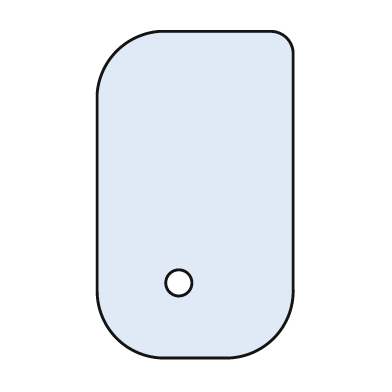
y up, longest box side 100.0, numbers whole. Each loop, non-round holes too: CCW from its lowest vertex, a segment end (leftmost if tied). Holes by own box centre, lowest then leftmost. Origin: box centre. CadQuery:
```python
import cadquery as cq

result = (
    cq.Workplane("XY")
    .moveTo(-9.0, -50.0)
    .lineTo(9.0, -50.0)
    .threePointArc((24.0, -44.0), (30.0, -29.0))
    .lineTo(30.0, 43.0)
    .threePointArc((28.0, 48.0), (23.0, 50.0))
    .lineTo(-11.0, 50.0)
    .threePointArc((-24.0, 44.0), (-30.0, 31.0))
    .lineTo(-30.0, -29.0)
    .threePointArc((-24.0, -44.0), (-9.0, -50.0))
    .close()
    .moveTo(-5.0, -27.0)
    .circle(4.0)
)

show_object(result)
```